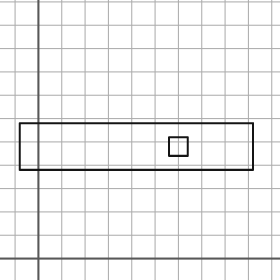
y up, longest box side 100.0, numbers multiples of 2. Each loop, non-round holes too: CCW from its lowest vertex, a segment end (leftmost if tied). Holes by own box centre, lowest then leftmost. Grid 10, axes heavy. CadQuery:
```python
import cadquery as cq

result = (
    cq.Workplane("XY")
    .moveTo(-8.0, 38.0)
    .lineTo(92.0, 38.0)
    .lineTo(92.0, 58.0)
    .lineTo(-8.0, 58.0)
    .close()
    .moveTo(56.0, 44.0)
    .lineTo(64.0, 44.0)
    .lineTo(64.0, 52.0)
    .lineTo(56.0, 52.0)
    .close()
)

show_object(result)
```